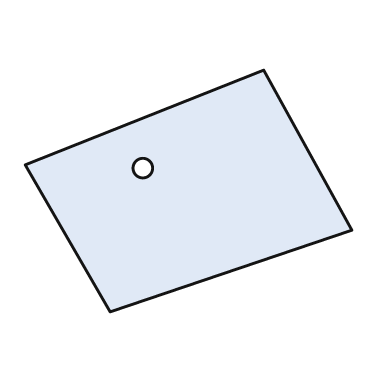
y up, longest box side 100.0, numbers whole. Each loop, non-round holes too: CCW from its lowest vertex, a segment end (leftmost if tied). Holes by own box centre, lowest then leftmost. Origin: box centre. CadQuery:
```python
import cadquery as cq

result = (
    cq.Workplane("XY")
    .moveTo(-24.0, -37.0)
    .lineTo(50.0, -12.0)
    .lineTo(23.0, 37.0)
    .lineTo(-50.0, 8.0)
    .close()
    .moveTo(-14.0, 7.0)
    .circle(3.0)
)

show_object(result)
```